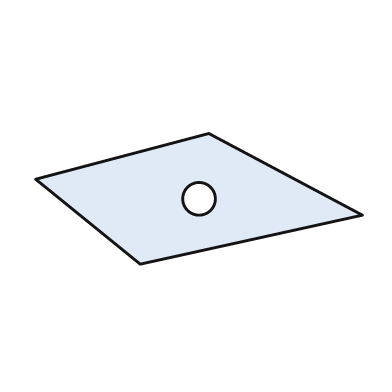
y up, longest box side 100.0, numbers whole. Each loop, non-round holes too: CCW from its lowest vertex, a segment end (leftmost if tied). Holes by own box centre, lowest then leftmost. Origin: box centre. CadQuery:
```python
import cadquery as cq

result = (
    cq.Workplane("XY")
    .moveTo(-18.0, -20.0)
    .lineTo(50.0, -5.0)
    .lineTo(3.0, 20.0)
    .lineTo(-50.0, 6.0)
    .close()
    .moveTo(0.0, 0.0)
    .circle(5.0)
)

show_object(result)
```